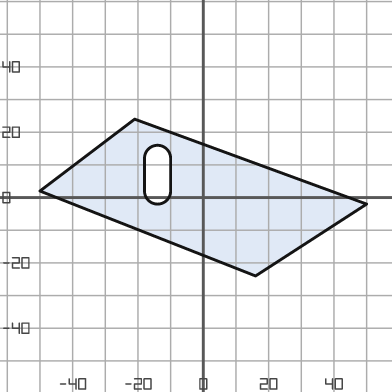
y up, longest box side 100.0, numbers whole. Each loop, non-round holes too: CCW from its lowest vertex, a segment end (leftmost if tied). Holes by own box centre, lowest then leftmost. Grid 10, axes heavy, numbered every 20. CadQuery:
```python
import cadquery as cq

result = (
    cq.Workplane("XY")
    .moveTo(16.0, -24.0)
    .lineTo(50.0, -2.0)
    .lineTo(-21.0, 24.0)
    .lineTo(-50.0, 2.0)
    .close()
    .moveTo(-18.0, 2.0)
    .threePointArc((-14.0, -2.0), (-10.0, 2.0))
    .lineTo(-10.0, 12.0)
    .threePointArc((-14.0, 16.0), (-18.0, 12.0))
    .close()
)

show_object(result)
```